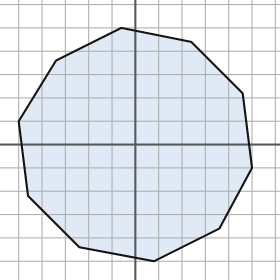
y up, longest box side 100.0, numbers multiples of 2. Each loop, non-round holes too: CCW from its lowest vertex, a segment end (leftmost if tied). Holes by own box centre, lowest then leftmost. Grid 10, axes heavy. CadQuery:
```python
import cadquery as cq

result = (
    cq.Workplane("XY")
    .moveTo(8.0, -50.0)
    .lineTo(36.0, -36.0)
    .lineTo(50.0, -10.0)
    .lineTo(46.0, 22.0)
    .lineTo(24.0, 44.0)
    .lineTo(-6.0, 50.0)
    .lineTo(-34.0, 36.0)
    .lineTo(-50.0, 10.0)
    .lineTo(-46.0, -22.0)
    .lineTo(-24.0, -44.0)
    .close()
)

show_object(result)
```